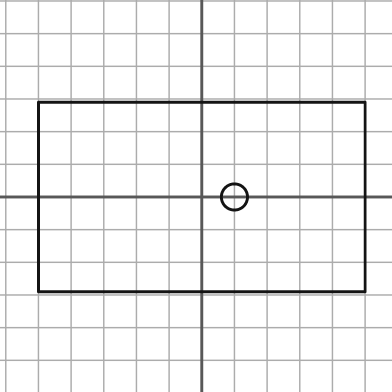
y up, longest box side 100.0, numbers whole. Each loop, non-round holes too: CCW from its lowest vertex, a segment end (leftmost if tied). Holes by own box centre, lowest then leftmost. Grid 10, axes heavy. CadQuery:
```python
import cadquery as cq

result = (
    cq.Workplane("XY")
    .moveTo(-50.0, -29.0)
    .lineTo(50.0, -29.0)
    .lineTo(50.0, 29.0)
    .lineTo(-50.0, 29.0)
    .close()
    .moveTo(10.0, 0.0)
    .circle(4.0)
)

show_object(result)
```